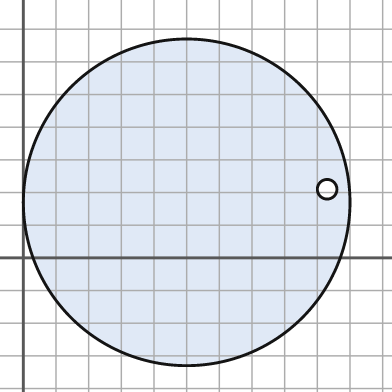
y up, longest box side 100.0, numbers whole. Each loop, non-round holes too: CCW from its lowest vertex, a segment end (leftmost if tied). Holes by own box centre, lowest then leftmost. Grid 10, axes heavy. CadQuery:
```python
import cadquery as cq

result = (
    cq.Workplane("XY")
    .moveTo(50.0, 17.0)
    .circle(50.0)
    .moveTo(93.0, 21.0)
    .circle(3.0)
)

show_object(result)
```